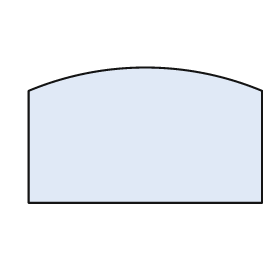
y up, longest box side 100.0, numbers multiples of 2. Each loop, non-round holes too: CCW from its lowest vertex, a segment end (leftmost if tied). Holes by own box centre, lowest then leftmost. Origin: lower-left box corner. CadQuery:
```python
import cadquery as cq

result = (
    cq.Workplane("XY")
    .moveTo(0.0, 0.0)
    .lineTo(100.0, 0.0)
    .lineTo(100.0, 48.0)
    .threePointArc((50.0, 58.0), (0.0, 48.0))
    .close()
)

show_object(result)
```